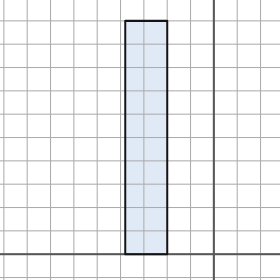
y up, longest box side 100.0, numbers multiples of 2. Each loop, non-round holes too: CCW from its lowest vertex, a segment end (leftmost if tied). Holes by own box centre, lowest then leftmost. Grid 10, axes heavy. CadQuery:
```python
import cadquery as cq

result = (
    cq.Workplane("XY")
    .moveTo(-38.0, 0.0)
    .lineTo(-20.0, 0.0)
    .lineTo(-20.0, 100.0)
    .lineTo(-38.0, 100.0)
    .close()
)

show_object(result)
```